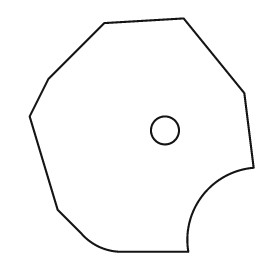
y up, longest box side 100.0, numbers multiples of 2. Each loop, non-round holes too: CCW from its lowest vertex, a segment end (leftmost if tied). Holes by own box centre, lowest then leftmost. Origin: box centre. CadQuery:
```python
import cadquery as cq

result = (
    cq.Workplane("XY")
    .moveTo(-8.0, -50.0)
    .lineTo(20.0, -50.0)
    .threePointArc((26.0, -26.0), (48.0, -14.0))
    .lineTo(44.0, 18.0)
    .lineTo(18.0, 50.0)
    .lineTo(-16.0, 48.0)
    .lineTo(-40.0, 24.0)
    .lineTo(-48.0, 8.0)
    .lineTo(-36.0, -32.0)
    .lineTo(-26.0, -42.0)
    .threePointArc((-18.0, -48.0), (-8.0, -50.0))
    .close()
    .moveTo(10.0, 2.0)
    .circle(6.0)
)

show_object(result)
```